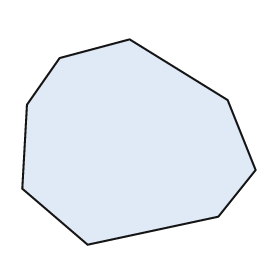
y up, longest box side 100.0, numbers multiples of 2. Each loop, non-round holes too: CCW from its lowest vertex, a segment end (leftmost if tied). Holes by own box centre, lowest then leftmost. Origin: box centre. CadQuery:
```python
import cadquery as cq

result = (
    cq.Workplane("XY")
    .moveTo(-22.0, -44.0)
    .lineTo(34.0, -32.0)
    .lineTo(50.0, -12.0)
    .lineTo(38.0, 18.0)
    .lineTo(-4.0, 44.0)
    .lineTo(-34.0, 36.0)
    .lineTo(-48.0, 16.0)
    .lineTo(-50.0, -20.0)
    .close()
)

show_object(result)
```